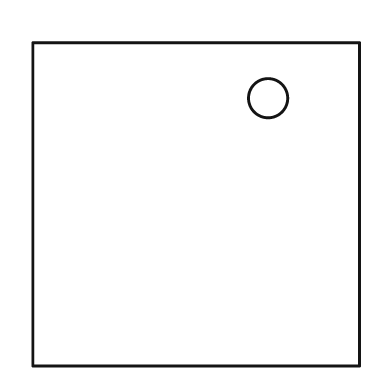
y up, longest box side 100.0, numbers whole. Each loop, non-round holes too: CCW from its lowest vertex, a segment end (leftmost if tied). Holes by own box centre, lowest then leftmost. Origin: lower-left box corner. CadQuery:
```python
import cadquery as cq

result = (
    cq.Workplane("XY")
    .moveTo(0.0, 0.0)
    .lineTo(100.0, 0.0)
    .lineTo(100.0, 99.0)
    .lineTo(0.0, 99.0)
    .close()
    .moveTo(72.0, 82.0)
    .circle(6.0)
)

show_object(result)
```